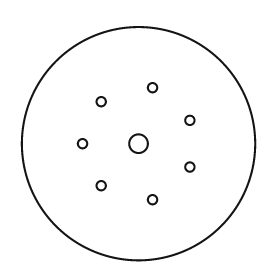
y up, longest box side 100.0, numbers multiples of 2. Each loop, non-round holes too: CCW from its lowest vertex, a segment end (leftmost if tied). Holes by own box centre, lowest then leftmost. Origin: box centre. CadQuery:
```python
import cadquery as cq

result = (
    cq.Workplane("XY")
    .moveTo(0.0, 0.0)
    .circle(50.0)
    .moveTo(6.0, -24.0)
    .circle(2.0)
    .moveTo(-16.0, -18.0)
    .circle(2.0)
    .moveTo(22.0, -10.0)
    .circle(2.0)
    .moveTo(-24.0, 0.0)
    .circle(2.0)
    .moveTo(0.0, 0.0)
    .circle(4.0)
    .moveTo(22.0, 10.0)
    .circle(2.0)
    .moveTo(-16.0, 18.0)
    .circle(2.0)
    .moveTo(6.0, 24.0)
    .circle(2.0)
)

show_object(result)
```